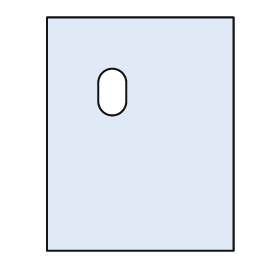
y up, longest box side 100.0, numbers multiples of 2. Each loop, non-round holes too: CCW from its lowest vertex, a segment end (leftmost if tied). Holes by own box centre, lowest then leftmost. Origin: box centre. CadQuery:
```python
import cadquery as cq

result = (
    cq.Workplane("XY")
    .moveTo(-40.0, -50.0)
    .lineTo(40.0, -50.0)
    .lineTo(40.0, 50.0)
    .lineTo(-40.0, 50.0)
    .close()
    .moveTo(-18.0, 14.0)
    .threePointArc((-12.0, 8.0), (-6.0, 14.0))
    .lineTo(-6.0, 22.0)
    .threePointArc((-12.0, 28.0), (-18.0, 22.0))
    .close()
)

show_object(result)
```